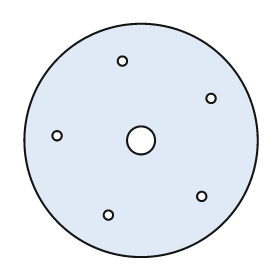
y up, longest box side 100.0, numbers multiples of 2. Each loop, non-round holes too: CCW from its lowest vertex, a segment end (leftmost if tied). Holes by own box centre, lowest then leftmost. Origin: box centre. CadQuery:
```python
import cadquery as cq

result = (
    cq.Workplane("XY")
    .moveTo(0.0, 0.0)
    .circle(50.0)
    .moveTo(-14.0, -32.0)
    .circle(2.0)
    .moveTo(26.0, -24.0)
    .circle(2.0)
    .moveTo(0.0, 0.0)
    .circle(6.0)
    .moveTo(-36.0, 2.0)
    .circle(2.0)
    .moveTo(30.0, 18.0)
    .circle(2.0)
    .moveTo(-8.0, 34.0)
    .circle(2.0)
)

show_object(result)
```